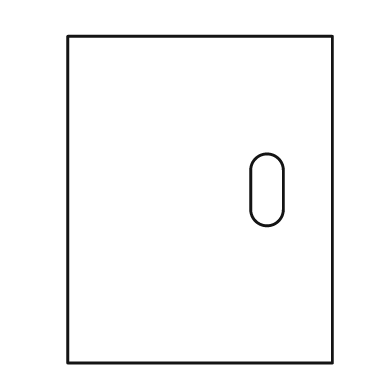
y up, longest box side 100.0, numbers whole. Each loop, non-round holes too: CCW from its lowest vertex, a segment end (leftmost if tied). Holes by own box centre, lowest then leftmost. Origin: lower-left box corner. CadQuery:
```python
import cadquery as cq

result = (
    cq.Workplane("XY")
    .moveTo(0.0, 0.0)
    .lineTo(81.0, 0.0)
    .lineTo(81.0, 100.0)
    .lineTo(0.0, 100.0)
    .close()
    .moveTo(56.0, 47.0)
    .threePointArc((61.0, 42.0), (66.0, 47.0))
    .lineTo(66.0, 59.0)
    .threePointArc((61.0, 64.0), (56.0, 59.0))
    .close()
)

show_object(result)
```